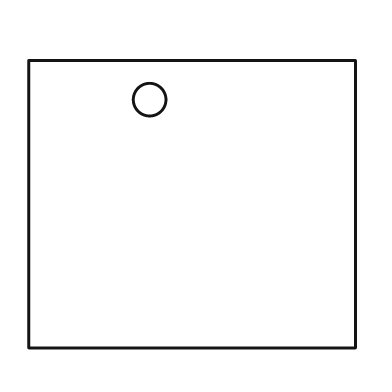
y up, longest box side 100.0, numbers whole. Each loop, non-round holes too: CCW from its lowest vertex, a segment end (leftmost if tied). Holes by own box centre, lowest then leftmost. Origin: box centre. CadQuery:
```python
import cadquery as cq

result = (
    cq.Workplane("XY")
    .moveTo(-50.0, -44.0)
    .lineTo(50.0, -44.0)
    .lineTo(50.0, 44.0)
    .lineTo(-50.0, 44.0)
    .close()
    .moveTo(-13.0, 32.0)
    .circle(5.0)
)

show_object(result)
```